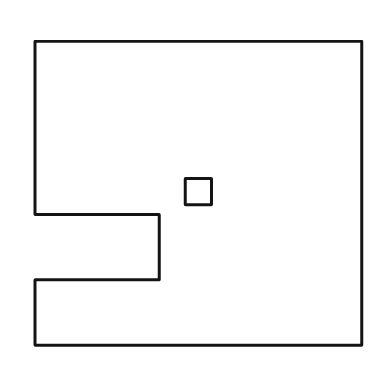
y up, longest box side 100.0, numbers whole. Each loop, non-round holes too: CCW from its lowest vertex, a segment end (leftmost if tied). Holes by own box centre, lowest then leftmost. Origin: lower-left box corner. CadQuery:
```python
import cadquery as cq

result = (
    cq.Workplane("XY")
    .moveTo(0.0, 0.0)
    .lineTo(100.0, 0.0)
    .lineTo(100.0, 93.0)
    .lineTo(0.0, 93.0)
    .lineTo(0.0, 40.0)
    .lineTo(38.0, 40.0)
    .lineTo(38.0, 20.0)
    .lineTo(0.0, 20.0)
    .close()
    .moveTo(46.0, 43.0)
    .lineTo(54.0, 43.0)
    .lineTo(54.0, 51.0)
    .lineTo(46.0, 51.0)
    .close()
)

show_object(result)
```